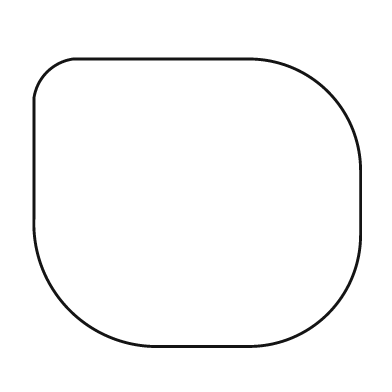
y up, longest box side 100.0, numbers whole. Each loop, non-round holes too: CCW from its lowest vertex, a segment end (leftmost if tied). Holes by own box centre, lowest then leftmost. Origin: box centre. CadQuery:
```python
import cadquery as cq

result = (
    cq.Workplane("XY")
    .moveTo(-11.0, -44.0)
    .lineTo(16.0, -44.0)
    .threePointArc((40.0, -34.0), (50.0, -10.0))
    .lineTo(50.0, 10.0)
    .threePointArc((40.0, 34.0), (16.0, 44.0))
    .lineTo(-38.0, 44.0)
    .threePointArc((-46.0, 40.0), (-50.0, 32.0))
    .lineTo(-50.0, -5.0)
    .threePointArc((-39.0, -33.0), (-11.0, -44.0))
    .close()
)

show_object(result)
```